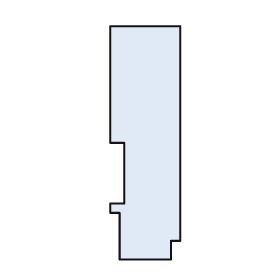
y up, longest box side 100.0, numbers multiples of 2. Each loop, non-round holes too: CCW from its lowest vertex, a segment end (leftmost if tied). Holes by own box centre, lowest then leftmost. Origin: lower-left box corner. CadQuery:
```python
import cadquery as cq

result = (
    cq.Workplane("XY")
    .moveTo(4.0, 0.0)
    .lineTo(26.0, 0.0)
    .lineTo(26.0, 8.0)
    .lineTo(30.0, 8.0)
    .lineTo(30.0, 100.0)
    .lineTo(0.0, 100.0)
    .lineTo(0.0, 50.0)
    .lineTo(6.0, 50.0)
    .lineTo(6.0, 24.0)
    .lineTo(0.0, 24.0)
    .lineTo(0.0, 20.0)
    .lineTo(4.0, 20.0)
    .close()
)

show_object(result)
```